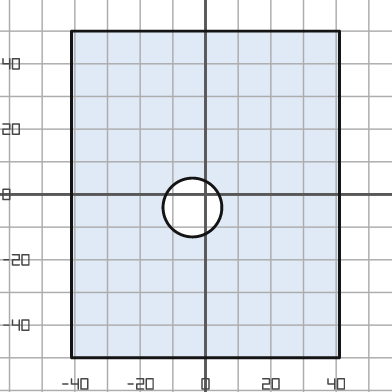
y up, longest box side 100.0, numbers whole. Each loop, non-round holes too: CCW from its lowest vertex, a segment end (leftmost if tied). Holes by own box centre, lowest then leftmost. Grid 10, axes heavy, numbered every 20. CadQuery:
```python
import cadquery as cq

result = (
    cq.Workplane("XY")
    .moveTo(-41.0, -50.0)
    .lineTo(41.0, -50.0)
    .lineTo(41.0, 50.0)
    .lineTo(-41.0, 50.0)
    .close()
    .moveTo(-4.0, -4.0)
    .circle(9.0)
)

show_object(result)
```